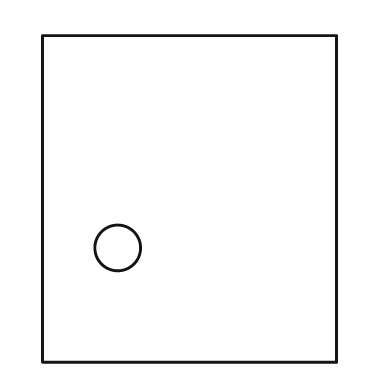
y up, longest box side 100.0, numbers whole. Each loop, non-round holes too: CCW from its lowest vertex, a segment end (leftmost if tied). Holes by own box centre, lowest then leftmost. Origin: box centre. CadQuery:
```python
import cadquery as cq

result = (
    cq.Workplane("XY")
    .moveTo(-45.0, -50.0)
    .lineTo(45.0, -50.0)
    .lineTo(45.0, 50.0)
    .lineTo(-45.0, 50.0)
    .close()
    .moveTo(-22.0, -15.0)
    .circle(7.0)
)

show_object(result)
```